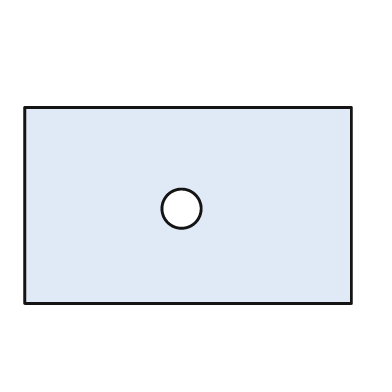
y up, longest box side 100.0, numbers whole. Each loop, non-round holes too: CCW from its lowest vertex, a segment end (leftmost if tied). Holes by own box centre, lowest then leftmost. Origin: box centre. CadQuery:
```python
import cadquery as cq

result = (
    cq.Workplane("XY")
    .moveTo(-50.0, -30.0)
    .lineTo(50.0, -30.0)
    .lineTo(50.0, 30.0)
    .lineTo(-50.0, 30.0)
    .close()
    .moveTo(-2.0, -1.0)
    .circle(6.0)
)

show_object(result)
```